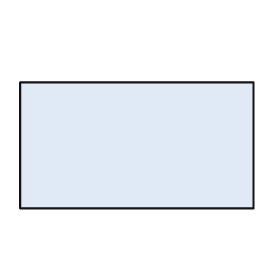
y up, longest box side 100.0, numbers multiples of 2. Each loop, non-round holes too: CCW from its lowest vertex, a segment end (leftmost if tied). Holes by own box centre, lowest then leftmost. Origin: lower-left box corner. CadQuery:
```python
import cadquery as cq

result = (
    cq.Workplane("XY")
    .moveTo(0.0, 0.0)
    .lineTo(100.0, 0.0)
    .lineTo(100.0, 54.0)
    .lineTo(0.0, 54.0)
    .close()
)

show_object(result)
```